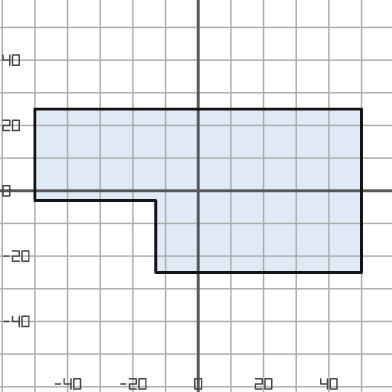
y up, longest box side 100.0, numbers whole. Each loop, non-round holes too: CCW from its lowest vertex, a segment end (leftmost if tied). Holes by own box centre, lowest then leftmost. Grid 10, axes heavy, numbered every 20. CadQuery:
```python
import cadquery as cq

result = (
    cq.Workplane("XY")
    .moveTo(-13.0, -25.0)
    .lineTo(50.0, -25.0)
    .lineTo(50.0, 25.0)
    .lineTo(-50.0, 25.0)
    .lineTo(-50.0, -3.0)
    .lineTo(-13.0, -3.0)
    .close()
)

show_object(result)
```